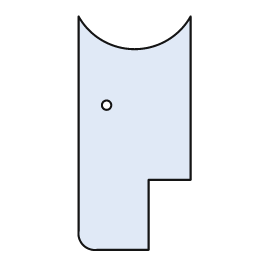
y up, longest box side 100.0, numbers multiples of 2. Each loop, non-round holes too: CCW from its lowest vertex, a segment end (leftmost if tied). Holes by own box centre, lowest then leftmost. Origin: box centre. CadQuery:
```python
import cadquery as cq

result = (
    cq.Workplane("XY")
    .moveTo(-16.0, -50.0)
    .lineTo(6.0, -50.0)
    .lineTo(6.0, -20.0)
    .lineTo(24.0, -20.0)
    .lineTo(24.0, 50.0)
    .threePointArc((0.0, 36.0), (-24.0, 50.0))
    .lineTo(-24.0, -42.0)
    .threePointArc((-22.0, -48.0), (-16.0, -50.0))
    .close()
    .moveTo(-12.0, 12.0)
    .circle(2.0)
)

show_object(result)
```